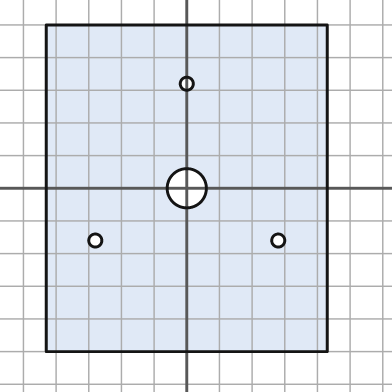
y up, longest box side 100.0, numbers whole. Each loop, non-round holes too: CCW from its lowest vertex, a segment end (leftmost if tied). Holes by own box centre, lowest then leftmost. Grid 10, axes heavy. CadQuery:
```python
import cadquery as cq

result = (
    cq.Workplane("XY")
    .moveTo(-43.0, -50.0)
    .lineTo(43.0, -50.0)
    .lineTo(43.0, 50.0)
    .lineTo(-43.0, 50.0)
    .close()
    .moveTo(-28.0, -16.0)
    .circle(2.0)
    .moveTo(28.0, -16.0)
    .circle(2.0)
    .moveTo(0.0, 0.0)
    .circle(6.0)
    .moveTo(0.0, 32.0)
    .circle(2.0)
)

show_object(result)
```